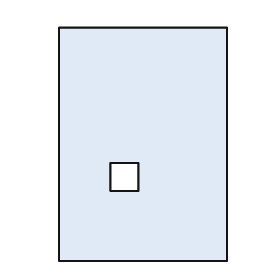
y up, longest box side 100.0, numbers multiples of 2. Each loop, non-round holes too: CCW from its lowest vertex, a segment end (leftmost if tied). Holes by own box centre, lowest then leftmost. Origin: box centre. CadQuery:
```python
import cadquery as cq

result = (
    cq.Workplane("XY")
    .moveTo(-36.0, -50.0)
    .lineTo(36.0, -50.0)
    .lineTo(36.0, 50.0)
    .lineTo(-36.0, 50.0)
    .close()
    .moveTo(-14.0, -20.0)
    .lineTo(-2.0, -20.0)
    .lineTo(-2.0, -8.0)
    .lineTo(-14.0, -8.0)
    .close()
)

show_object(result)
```